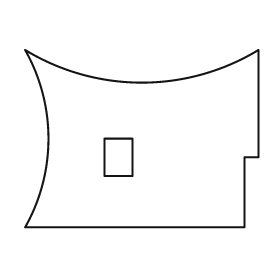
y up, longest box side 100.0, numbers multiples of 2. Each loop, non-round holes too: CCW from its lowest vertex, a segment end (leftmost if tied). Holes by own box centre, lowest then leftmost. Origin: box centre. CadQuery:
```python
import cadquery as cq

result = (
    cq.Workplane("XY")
    .moveTo(-50.0, -38.0)
    .lineTo(44.0, -38.0)
    .lineTo(44.0, -8.0)
    .lineTo(50.0, -8.0)
    .lineTo(50.0, 38.0)
    .threePointArc((0.0, 24.0), (-50.0, 38.0))
    .threePointArc((-40.0, 0.0), (-50.0, -38.0))
    .close()
    .moveTo(-16.0, -16.0)
    .lineTo(-4.0, -16.0)
    .lineTo(-4.0, 0.0)
    .lineTo(-16.0, 0.0)
    .close()
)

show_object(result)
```